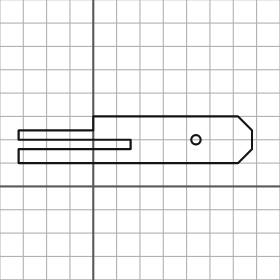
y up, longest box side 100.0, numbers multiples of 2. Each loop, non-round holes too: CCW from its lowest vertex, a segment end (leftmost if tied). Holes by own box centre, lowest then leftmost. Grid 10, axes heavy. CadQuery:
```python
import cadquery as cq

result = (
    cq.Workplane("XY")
    .moveTo(-32.0, 10.0)
    .lineTo(62.0, 10.0)
    .lineTo(68.0, 16.0)
    .lineTo(68.0, 24.0)
    .lineTo(62.0, 30.0)
    .lineTo(0.0, 30.0)
    .lineTo(0.0, 24.0)
    .lineTo(-32.0, 24.0)
    .lineTo(-32.0, 20.0)
    .lineTo(16.0, 20.0)
    .lineTo(16.0, 16.0)
    .lineTo(-32.0, 16.0)
    .close()
    .moveTo(44.0, 20.0)
    .circle(2.0)
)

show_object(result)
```